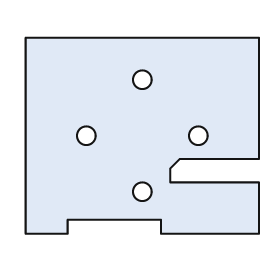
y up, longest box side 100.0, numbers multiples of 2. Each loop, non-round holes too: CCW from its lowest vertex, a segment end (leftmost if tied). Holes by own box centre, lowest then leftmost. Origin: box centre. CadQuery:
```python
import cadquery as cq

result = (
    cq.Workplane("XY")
    .moveTo(-50.0, -42.0)
    .lineTo(-32.0, -42.0)
    .lineTo(-32.0, -36.0)
    .lineTo(8.0, -36.0)
    .lineTo(8.0, -42.0)
    .lineTo(50.0, -42.0)
    .lineTo(50.0, -20.0)
    .lineTo(12.0, -20.0)
    .lineTo(12.0, -14.0)
    .lineTo(16.0, -10.0)
    .lineTo(50.0, -10.0)
    .lineTo(50.0, 42.0)
    .lineTo(-50.0, 42.0)
    .close()
    .moveTo(0.0, -24.0)
    .circle(4.0)
    .moveTo(-24.0, 0.0)
    .circle(4.0)
    .moveTo(24.0, 0.0)
    .circle(4.0)
    .moveTo(0.0, 24.0)
    .circle(4.0)
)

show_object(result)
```